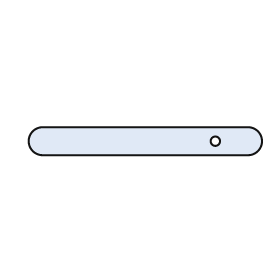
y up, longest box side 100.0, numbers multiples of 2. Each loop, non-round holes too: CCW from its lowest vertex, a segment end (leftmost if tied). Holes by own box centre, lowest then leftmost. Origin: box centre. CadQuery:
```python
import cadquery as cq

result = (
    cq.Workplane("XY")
    .moveTo(-44.0, -6.0)
    .lineTo(44.0, -6.0)
    .threePointArc((50.0, 0.0), (44.0, 6.0))
    .lineTo(-44.0, 6.0)
    .threePointArc((-50.0, 0.0), (-44.0, -6.0))
    .close()
    .moveTo(30.0, 0.0)
    .circle(2.0)
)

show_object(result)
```